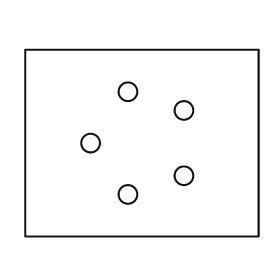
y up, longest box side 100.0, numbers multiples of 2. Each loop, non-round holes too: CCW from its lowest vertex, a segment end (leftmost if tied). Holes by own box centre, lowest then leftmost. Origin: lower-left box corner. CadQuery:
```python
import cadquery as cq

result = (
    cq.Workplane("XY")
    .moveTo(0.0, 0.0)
    .lineTo(100.0, 0.0)
    .lineTo(100.0, 80.0)
    .lineTo(0.0, 80.0)
    .close()
    .moveTo(44.0, 18.0)
    .circle(4.0)
    .moveTo(68.0, 26.0)
    .circle(4.0)
    .moveTo(28.0, 40.0)
    .circle(4.0)
    .moveTo(68.0, 54.0)
    .circle(4.0)
    .moveTo(44.0, 62.0)
    .circle(4.0)
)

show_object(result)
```